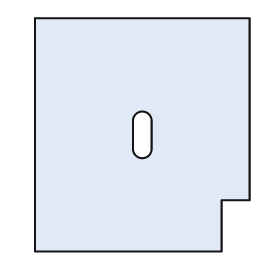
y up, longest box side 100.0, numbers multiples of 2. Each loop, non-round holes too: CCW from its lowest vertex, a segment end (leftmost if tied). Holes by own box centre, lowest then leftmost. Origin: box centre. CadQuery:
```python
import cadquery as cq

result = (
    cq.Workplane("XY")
    .moveTo(-46.0, -50.0)
    .lineTo(34.0, -50.0)
    .lineTo(34.0, -28.0)
    .lineTo(46.0, -28.0)
    .lineTo(46.0, 50.0)
    .lineTo(-46.0, 50.0)
    .close()
    .moveTo(-4.0, -6.0)
    .threePointArc((0.0, -10.0), (4.0, -6.0))
    .lineTo(4.0, 6.0)
    .threePointArc((0.0, 10.0), (-4.0, 6.0))
    .close()
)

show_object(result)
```